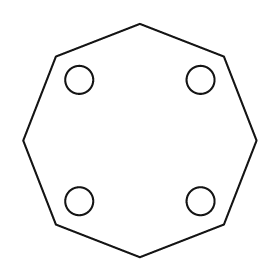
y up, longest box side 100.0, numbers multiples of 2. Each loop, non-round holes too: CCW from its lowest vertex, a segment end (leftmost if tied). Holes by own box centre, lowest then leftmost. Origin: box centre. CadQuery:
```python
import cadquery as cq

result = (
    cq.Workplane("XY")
    .moveTo(0.0, -50.0)
    .lineTo(36.0, -36.0)
    .lineTo(50.0, 0.0)
    .lineTo(36.0, 36.0)
    .lineTo(0.0, 50.0)
    .lineTo(-36.0, 36.0)
    .lineTo(-50.0, 0.0)
    .lineTo(-36.0, -36.0)
    .close()
    .moveTo(-26.0, -26.0)
    .circle(6.0)
    .moveTo(26.0, -26.0)
    .circle(6.0)
    .moveTo(-26.0, 26.0)
    .circle(6.0)
    .moveTo(26.0, 26.0)
    .circle(6.0)
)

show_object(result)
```